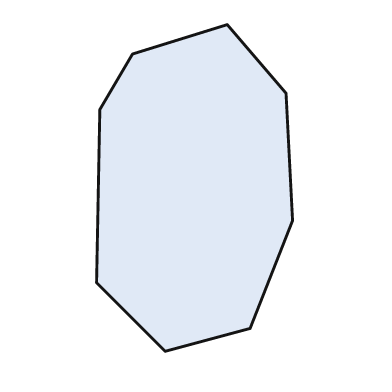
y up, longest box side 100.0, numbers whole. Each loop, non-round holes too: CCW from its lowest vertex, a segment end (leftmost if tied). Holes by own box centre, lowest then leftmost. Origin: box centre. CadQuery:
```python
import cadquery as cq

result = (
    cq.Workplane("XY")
    .moveTo(-9.0, -50.0)
    .lineTo(17.0, -43.0)
    .lineTo(30.0, -10.0)
    .lineTo(28.0, 29.0)
    .lineTo(10.0, 50.0)
    .lineTo(-19.0, 41.0)
    .lineTo(-29.0, 24.0)
    .lineTo(-30.0, -29.0)
    .close()
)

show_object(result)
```